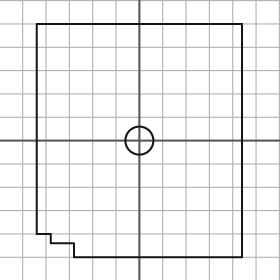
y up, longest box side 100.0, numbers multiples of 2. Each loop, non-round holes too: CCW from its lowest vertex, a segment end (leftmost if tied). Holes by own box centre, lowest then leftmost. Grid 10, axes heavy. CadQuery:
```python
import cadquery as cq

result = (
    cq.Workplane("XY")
    .moveTo(-28.0, -50.0)
    .lineTo(44.0, -50.0)
    .lineTo(44.0, 50.0)
    .lineTo(-44.0, 50.0)
    .lineTo(-44.0, -40.0)
    .lineTo(-38.0, -40.0)
    .lineTo(-38.0, -44.0)
    .lineTo(-28.0, -44.0)
    .close()
    .moveTo(0.0, 0.0)
    .circle(6.0)
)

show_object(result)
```